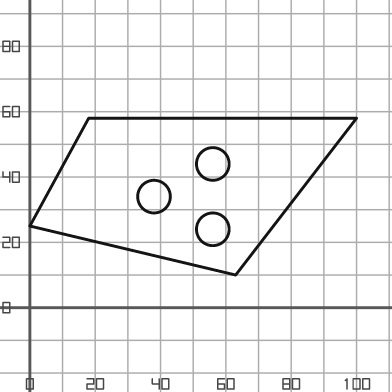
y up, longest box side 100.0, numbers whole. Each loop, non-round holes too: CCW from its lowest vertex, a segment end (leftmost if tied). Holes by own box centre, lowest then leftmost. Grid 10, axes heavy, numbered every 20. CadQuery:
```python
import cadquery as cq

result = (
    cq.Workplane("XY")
    .moveTo(63.0, 10.0)
    .lineTo(100.0, 58.0)
    .lineTo(18.0, 58.0)
    .lineTo(0.0, 25.0)
    .close()
    .moveTo(56.0, 24.0)
    .circle(5.0)
    .moveTo(38.0, 34.0)
    .circle(5.0)
    .moveTo(56.0, 44.0)
    .circle(5.0)
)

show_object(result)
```